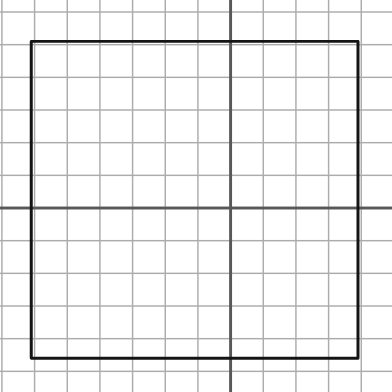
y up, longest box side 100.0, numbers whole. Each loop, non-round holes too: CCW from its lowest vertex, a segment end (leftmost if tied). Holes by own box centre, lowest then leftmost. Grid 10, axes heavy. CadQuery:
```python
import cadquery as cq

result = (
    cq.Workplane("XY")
    .moveTo(-61.0, -46.0)
    .lineTo(39.0, -46.0)
    .lineTo(39.0, 51.0)
    .lineTo(-61.0, 51.0)
    .close()
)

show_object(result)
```